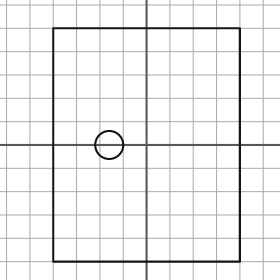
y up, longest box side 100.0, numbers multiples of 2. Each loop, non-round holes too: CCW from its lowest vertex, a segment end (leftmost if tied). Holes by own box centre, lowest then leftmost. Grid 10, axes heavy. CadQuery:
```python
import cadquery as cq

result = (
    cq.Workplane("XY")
    .moveTo(-40.0, -50.0)
    .lineTo(40.0, -50.0)
    .lineTo(40.0, 50.0)
    .lineTo(-40.0, 50.0)
    .close()
    .moveTo(-16.0, 0.0)
    .circle(6.0)
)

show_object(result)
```